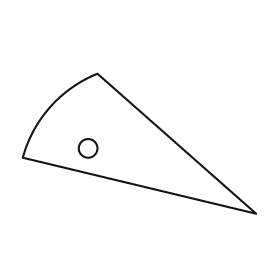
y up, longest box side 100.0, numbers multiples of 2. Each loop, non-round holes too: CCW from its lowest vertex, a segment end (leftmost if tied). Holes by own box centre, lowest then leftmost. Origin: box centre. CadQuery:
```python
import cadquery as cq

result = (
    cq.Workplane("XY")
    .moveTo(50.0, -30.0)
    .lineTo(-18.0, 30.0)
    .threePointArc((-38.0, 16.0), (-50.0, -6.0))
    .close()
    .moveTo(-22.0, -2.0)
    .circle(4.0)
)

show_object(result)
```